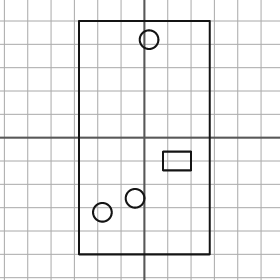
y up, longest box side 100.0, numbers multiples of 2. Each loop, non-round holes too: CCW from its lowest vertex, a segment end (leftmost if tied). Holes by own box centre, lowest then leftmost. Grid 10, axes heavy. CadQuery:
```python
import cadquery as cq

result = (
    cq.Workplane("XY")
    .moveTo(-28.0, -50.0)
    .lineTo(28.0, -50.0)
    .lineTo(28.0, 50.0)
    .lineTo(-28.0, 50.0)
    .close()
    .moveTo(-18.0, -32.0)
    .circle(4.0)
    .moveTo(-4.0, -26.0)
    .circle(4.0)
    .moveTo(8.0, -14.0)
    .lineTo(20.0, -14.0)
    .lineTo(20.0, -6.0)
    .lineTo(8.0, -6.0)
    .close()
    .moveTo(2.0, 42.0)
    .circle(4.0)
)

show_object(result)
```